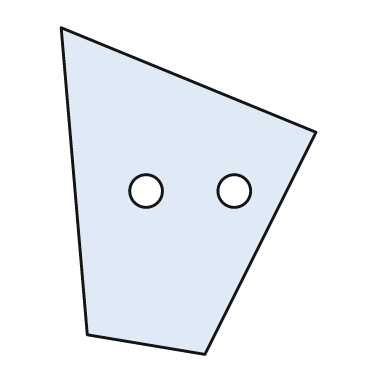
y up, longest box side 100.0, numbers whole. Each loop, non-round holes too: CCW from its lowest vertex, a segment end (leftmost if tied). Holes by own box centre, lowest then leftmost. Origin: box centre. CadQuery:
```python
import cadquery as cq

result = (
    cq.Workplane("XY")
    .moveTo(5.0, -50.0)
    .lineTo(39.0, 18.0)
    .lineTo(-39.0, 50.0)
    .lineTo(-31.0, -44.0)
    .close()
    .moveTo(-13.0, 0.0)
    .circle(5.0)
    .moveTo(14.0, 0.0)
    .circle(5.0)
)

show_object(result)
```